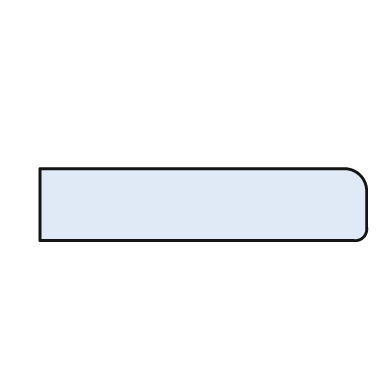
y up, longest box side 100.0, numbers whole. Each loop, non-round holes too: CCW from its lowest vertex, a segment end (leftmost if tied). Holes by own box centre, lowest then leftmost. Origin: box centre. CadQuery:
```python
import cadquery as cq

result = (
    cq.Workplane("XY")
    .moveTo(-50.0, -11.0)
    .lineTo(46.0, -11.0)
    .threePointArc((49.0, -10.0), (50.0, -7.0))
    .lineTo(50.0, 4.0)
    .threePointArc((48.0, 9.0), (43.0, 11.0))
    .lineTo(-50.0, 11.0)
    .close()
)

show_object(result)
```